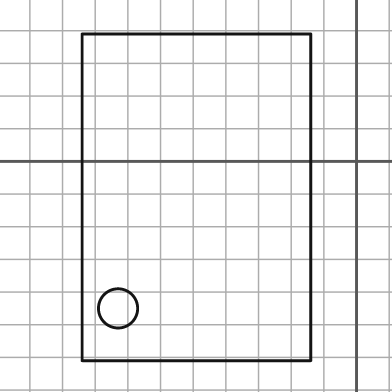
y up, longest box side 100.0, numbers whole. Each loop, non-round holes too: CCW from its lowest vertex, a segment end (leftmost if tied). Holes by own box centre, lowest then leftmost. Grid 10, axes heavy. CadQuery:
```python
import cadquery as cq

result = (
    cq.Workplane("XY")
    .moveTo(-84.0, -61.0)
    .lineTo(-14.0, -61.0)
    .lineTo(-14.0, 39.0)
    .lineTo(-84.0, 39.0)
    .close()
    .moveTo(-73.0, -45.0)
    .circle(6.0)
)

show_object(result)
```